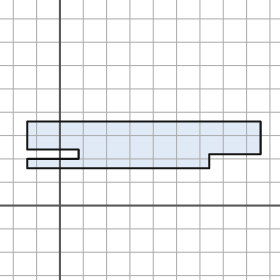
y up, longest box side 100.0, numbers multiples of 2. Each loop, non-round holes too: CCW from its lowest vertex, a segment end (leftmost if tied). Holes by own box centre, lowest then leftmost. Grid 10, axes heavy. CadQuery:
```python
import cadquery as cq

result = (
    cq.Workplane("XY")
    .moveTo(-14.0, 16.0)
    .lineTo(64.0, 16.0)
    .lineTo(64.0, 22.0)
    .lineTo(86.0, 22.0)
    .lineTo(86.0, 36.0)
    .lineTo(-14.0, 36.0)
    .lineTo(-14.0, 24.0)
    .lineTo(8.0, 24.0)
    .lineTo(8.0, 20.0)
    .lineTo(-14.0, 20.0)
    .close()
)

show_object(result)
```